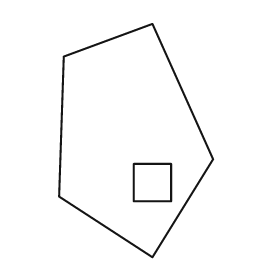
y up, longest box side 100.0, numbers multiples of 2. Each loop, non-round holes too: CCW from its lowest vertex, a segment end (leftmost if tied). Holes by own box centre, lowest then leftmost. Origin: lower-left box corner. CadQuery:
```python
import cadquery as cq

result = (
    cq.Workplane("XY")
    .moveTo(40.0, 0.0)
    .lineTo(66.0, 42.0)
    .lineTo(40.0, 100.0)
    .lineTo(2.0, 86.0)
    .lineTo(0.0, 26.0)
    .close()
    .moveTo(32.0, 24.0)
    .lineTo(48.0, 24.0)
    .lineTo(48.0, 40.0)
    .lineTo(32.0, 40.0)
    .close()
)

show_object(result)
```